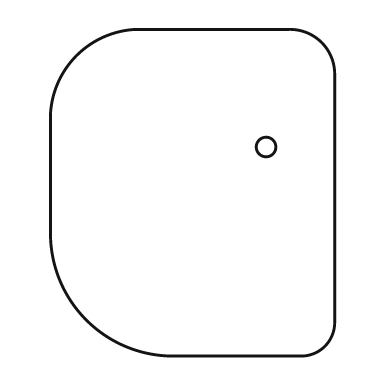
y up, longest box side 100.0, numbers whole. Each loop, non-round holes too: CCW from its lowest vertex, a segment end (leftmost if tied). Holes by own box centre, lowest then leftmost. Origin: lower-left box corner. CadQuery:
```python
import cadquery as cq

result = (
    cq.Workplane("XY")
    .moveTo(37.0, 0.0)
    .lineTo(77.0, 0.0)
    .threePointArc((84.0, 3.0), (87.0, 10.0))
    .lineTo(87.0, 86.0)
    .threePointArc((83.0, 96.0), (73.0, 100.0))
    .lineTo(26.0, 100.0)
    .threePointArc((8.0, 92.0), (0.0, 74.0))
    .lineTo(0.0, 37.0)
    .threePointArc((11.0, 11.0), (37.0, 0.0))
    .close()
    .moveTo(66.0, 64.0)
    .circle(3.0)
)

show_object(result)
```